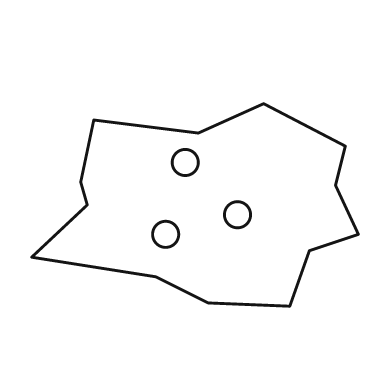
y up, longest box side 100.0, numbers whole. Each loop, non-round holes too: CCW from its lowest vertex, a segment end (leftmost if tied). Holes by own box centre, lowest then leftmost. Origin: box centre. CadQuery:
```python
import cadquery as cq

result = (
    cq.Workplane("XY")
    .moveTo(29.0, -31.0)
    .lineTo(35.0, -14.0)
    .lineTo(50.0, -9.0)
    .lineTo(43.0, 6.0)
    .lineTo(46.0, 18.0)
    .lineTo(21.0, 31.0)
    .lineTo(1.0, 22.0)
    .lineTo(-31.0, 26.0)
    .lineTo(-35.0, 7.0)
    .lineTo(-33.0, 0.0)
    .lineTo(-50.0, -16.0)
    .lineTo(-12.0, -22.0)
    .lineTo(4.0, -30.0)
    .close()
    .moveTo(-9.0, -9.0)
    .circle(4.0)
    .moveTo(13.0, -3.0)
    .circle(4.0)
    .moveTo(-3.0, 13.0)
    .circle(4.0)
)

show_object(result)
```